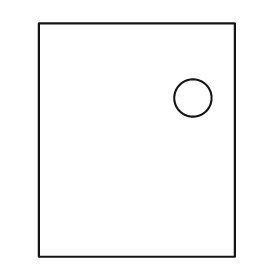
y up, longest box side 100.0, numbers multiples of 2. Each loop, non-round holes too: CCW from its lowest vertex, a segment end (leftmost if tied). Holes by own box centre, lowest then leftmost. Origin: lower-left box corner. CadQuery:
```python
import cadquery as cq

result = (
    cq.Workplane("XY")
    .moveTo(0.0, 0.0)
    .lineTo(84.0, 0.0)
    .lineTo(84.0, 100.0)
    .lineTo(0.0, 100.0)
    .close()
    .moveTo(66.0, 68.0)
    .circle(8.0)
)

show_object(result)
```